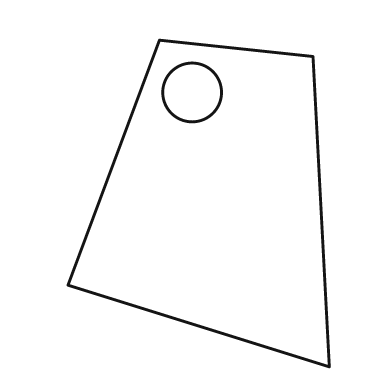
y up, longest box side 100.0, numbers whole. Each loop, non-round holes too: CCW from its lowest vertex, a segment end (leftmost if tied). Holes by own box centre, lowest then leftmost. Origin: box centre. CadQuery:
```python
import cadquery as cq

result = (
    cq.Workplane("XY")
    .moveTo(40.0, -50.0)
    .lineTo(35.0, 45.0)
    .lineTo(-12.0, 50.0)
    .lineTo(-40.0, -25.0)
    .close()
    .moveTo(-2.0, 34.0)
    .circle(9.0)
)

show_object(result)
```